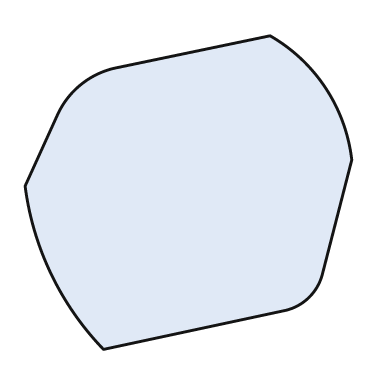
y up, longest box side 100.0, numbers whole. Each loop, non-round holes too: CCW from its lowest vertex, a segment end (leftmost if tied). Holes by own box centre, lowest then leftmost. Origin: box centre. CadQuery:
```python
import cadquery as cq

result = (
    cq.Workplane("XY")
    .moveTo(-26.0, -48.0)
    .lineTo(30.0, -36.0)
    .threePointArc((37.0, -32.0), (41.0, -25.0))
    .lineTo(50.0, 10.0)
    .threePointArc((42.0, 32.0), (25.0, 48.0))
    .lineTo(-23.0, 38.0)
    .threePointArc((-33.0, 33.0), (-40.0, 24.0))
    .lineTo(-50.0, 2.0)
    .threePointArc((-42.0, -25.0), (-26.0, -48.0))
    .close()
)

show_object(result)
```